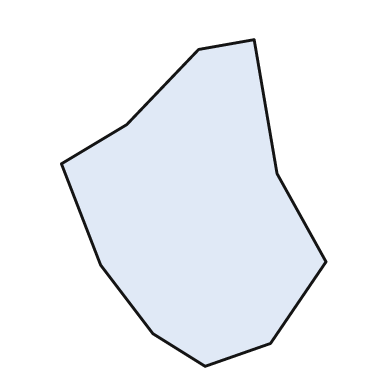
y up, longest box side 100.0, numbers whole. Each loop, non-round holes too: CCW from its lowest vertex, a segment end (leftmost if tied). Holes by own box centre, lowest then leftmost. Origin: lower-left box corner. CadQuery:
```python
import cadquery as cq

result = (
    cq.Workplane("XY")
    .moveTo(44.0, 0.0)
    .lineTo(64.0, 7.0)
    .lineTo(81.0, 32.0)
    .lineTo(66.0, 59.0)
    .lineTo(59.0, 100.0)
    .lineTo(42.0, 97.0)
    .lineTo(20.0, 74.0)
    .lineTo(0.0, 62.0)
    .lineTo(12.0, 31.0)
    .lineTo(28.0, 10.0)
    .close()
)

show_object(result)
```